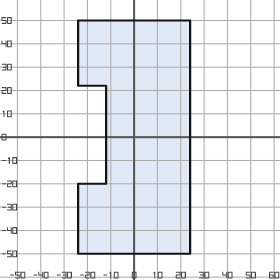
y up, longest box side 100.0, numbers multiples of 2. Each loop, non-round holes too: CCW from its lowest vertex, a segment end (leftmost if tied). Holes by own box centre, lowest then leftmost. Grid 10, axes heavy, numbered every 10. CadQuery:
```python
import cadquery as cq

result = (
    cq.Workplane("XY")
    .moveTo(-24.0, -50.0)
    .lineTo(24.0, -50.0)
    .lineTo(24.0, 50.0)
    .lineTo(-24.0, 50.0)
    .lineTo(-24.0, 22.0)
    .lineTo(-12.0, 22.0)
    .lineTo(-12.0, -20.0)
    .lineTo(-24.0, -20.0)
    .close()
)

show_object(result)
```